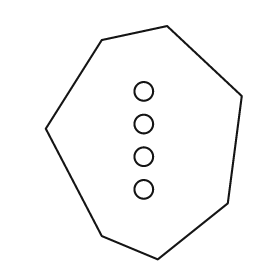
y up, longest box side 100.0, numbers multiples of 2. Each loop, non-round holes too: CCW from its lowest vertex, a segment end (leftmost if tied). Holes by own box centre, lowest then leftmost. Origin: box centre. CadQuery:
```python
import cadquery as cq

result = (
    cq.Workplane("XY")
    .moveTo(6.0, -50.0)
    .lineTo(36.0, -26.0)
    .lineTo(42.0, 20.0)
    .lineTo(10.0, 50.0)
    .lineTo(-18.0, 44.0)
    .lineTo(-42.0, 6.0)
    .lineTo(-18.0, -40.0)
    .close()
    .moveTo(0.0, -20.0)
    .circle(4.0)
    .moveTo(0.0, -6.0)
    .circle(4.0)
    .moveTo(0.0, 8.0)
    .circle(4.0)
    .moveTo(0.0, 22.0)
    .circle(4.0)
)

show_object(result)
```